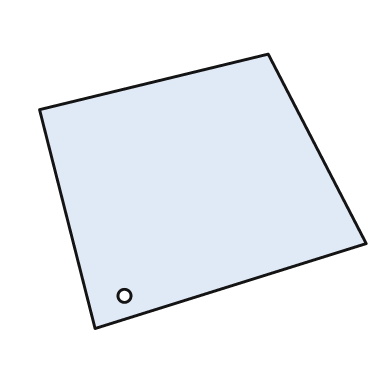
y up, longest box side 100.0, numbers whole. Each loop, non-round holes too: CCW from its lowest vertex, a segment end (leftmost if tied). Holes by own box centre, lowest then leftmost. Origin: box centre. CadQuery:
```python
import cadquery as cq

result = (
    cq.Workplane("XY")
    .moveTo(-33.0, -42.0)
    .lineTo(50.0, -16.0)
    .lineTo(20.0, 42.0)
    .lineTo(-50.0, 25.0)
    .close()
    .moveTo(-24.0, -32.0)
    .circle(2.0)
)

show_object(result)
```